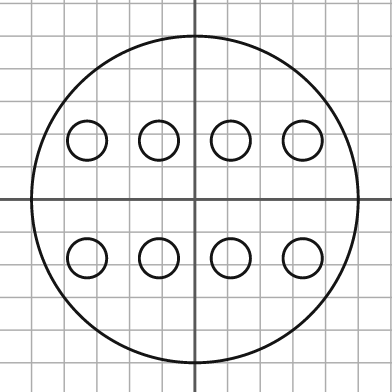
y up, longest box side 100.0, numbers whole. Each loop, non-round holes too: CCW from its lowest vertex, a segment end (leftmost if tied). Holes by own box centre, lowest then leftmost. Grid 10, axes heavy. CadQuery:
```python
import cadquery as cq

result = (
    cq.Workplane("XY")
    .moveTo(0.0, 0.0)
    .circle(50.0)
    .moveTo(-33.0, -18.0)
    .circle(6.0)
    .moveTo(-11.0, -18.0)
    .circle(6.0)
    .moveTo(11.0, -18.0)
    .circle(6.0)
    .moveTo(33.0, -18.0)
    .circle(6.0)
    .moveTo(-33.0, 18.0)
    .circle(6.0)
    .moveTo(-11.0, 18.0)
    .circle(6.0)
    .moveTo(11.0, 18.0)
    .circle(6.0)
    .moveTo(33.0, 18.0)
    .circle(6.0)
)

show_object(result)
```